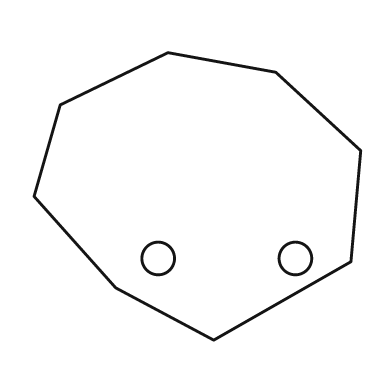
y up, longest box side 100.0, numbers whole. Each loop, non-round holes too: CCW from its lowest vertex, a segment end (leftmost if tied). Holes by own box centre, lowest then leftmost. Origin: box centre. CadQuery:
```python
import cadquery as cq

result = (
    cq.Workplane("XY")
    .moveTo(5.0, -44.0)
    .lineTo(47.0, -20.0)
    .lineTo(50.0, 14.0)
    .lineTo(24.0, 38.0)
    .lineTo(-9.0, 44.0)
    .lineTo(-42.0, 28.0)
    .lineTo(-50.0, 0.0)
    .lineTo(-25.0, -28.0)
    .close()
    .moveTo(-12.0, -19.0)
    .circle(5.0)
    .moveTo(30.0, -19.0)
    .circle(5.0)
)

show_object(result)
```